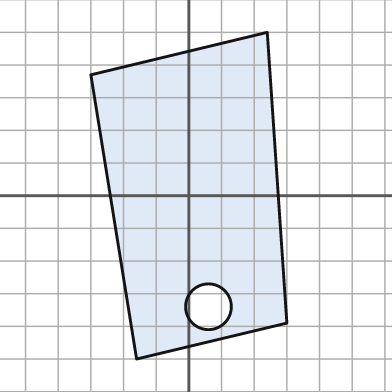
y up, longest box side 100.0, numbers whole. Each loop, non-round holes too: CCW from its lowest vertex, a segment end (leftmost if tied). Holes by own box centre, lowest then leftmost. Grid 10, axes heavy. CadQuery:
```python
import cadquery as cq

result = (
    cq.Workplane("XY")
    .moveTo(-16.0, -50.0)
    .lineTo(30.0, -39.0)
    .lineTo(24.0, 50.0)
    .lineTo(-30.0, 37.0)
    .close()
    .moveTo(6.0, -34.0)
    .circle(7.0)
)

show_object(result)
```